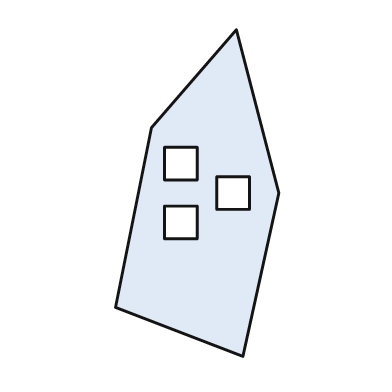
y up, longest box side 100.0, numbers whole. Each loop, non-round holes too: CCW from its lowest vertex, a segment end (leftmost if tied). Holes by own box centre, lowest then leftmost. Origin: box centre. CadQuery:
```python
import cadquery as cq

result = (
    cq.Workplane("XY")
    .moveTo(14.0, -50.0)
    .lineTo(25.0, 0.0)
    .lineTo(12.0, 50.0)
    .lineTo(-14.0, 20.0)
    .lineTo(-25.0, -35.0)
    .close()
    .moveTo(-10.0, -14.0)
    .lineTo(0.0, -14.0)
    .lineTo(0.0, -4.0)
    .lineTo(-10.0, -4.0)
    .close()
    .moveTo(6.0, -5.0)
    .lineTo(16.0, -5.0)
    .lineTo(16.0, 5.0)
    .lineTo(6.0, 5.0)
    .close()
    .moveTo(-10.0, 4.0)
    .lineTo(0.0, 4.0)
    .lineTo(0.0, 14.0)
    .lineTo(-10.0, 14.0)
    .close()
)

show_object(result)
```